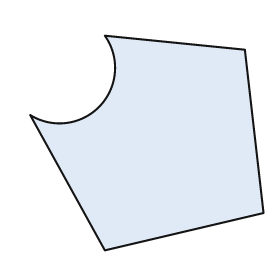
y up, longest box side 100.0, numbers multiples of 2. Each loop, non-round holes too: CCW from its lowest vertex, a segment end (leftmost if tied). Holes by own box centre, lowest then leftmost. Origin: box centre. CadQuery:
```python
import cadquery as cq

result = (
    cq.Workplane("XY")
    .moveTo(-18.0, -46.0)
    .lineTo(50.0, -30.0)
    .lineTo(42.0, 40.0)
    .lineTo(-18.0, 46.0)
    .threePointArc((-20.0, 16.0), (-50.0, 12.0))
    .close()
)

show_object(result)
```